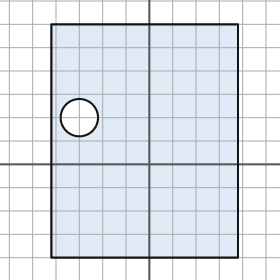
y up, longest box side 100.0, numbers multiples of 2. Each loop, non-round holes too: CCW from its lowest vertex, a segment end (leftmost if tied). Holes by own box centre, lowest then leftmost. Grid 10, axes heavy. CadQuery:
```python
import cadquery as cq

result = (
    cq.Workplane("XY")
    .moveTo(-42.0, -40.0)
    .lineTo(38.0, -40.0)
    .lineTo(38.0, 60.0)
    .lineTo(-42.0, 60.0)
    .close()
    .moveTo(-30.0, 20.0)
    .circle(8.0)
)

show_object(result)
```